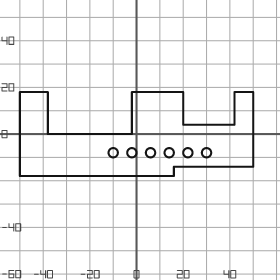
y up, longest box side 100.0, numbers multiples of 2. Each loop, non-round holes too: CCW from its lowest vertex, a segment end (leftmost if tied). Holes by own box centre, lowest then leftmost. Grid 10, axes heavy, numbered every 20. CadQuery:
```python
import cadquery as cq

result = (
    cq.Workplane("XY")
    .moveTo(-50.0, -18.0)
    .lineTo(16.0, -18.0)
    .lineTo(16.0, -14.0)
    .lineTo(50.0, -14.0)
    .lineTo(50.0, 18.0)
    .lineTo(42.0, 18.0)
    .lineTo(42.0, 4.0)
    .lineTo(20.0, 4.0)
    .lineTo(20.0, 18.0)
    .lineTo(-2.0, 18.0)
    .lineTo(-2.0, 0.0)
    .lineTo(-38.0, 0.0)
    .lineTo(-38.0, 18.0)
    .lineTo(-50.0, 18.0)
    .close()
    .moveTo(-10.0, -8.0)
    .circle(2.0)
    .moveTo(-2.0, -8.0)
    .circle(2.0)
    .moveTo(6.0, -8.0)
    .circle(2.0)
    .moveTo(14.0, -8.0)
    .circle(2.0)
    .moveTo(22.0, -8.0)
    .circle(2.0)
    .moveTo(30.0, -8.0)
    .circle(2.0)
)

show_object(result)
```